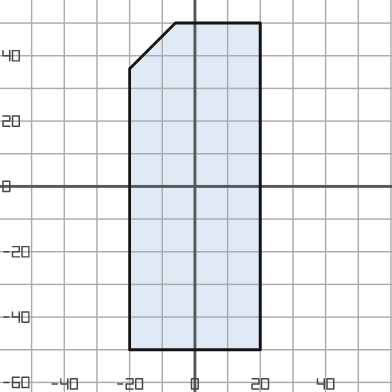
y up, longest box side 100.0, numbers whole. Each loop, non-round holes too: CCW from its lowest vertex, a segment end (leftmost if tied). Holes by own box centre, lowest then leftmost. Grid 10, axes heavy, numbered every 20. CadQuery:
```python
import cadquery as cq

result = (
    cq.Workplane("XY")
    .moveTo(-20.0, -50.0)
    .lineTo(20.0, -50.0)
    .lineTo(20.0, 50.0)
    .lineTo(-6.0, 50.0)
    .lineTo(-20.0, 36.0)
    .close()
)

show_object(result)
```